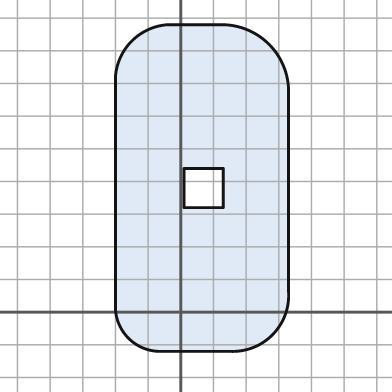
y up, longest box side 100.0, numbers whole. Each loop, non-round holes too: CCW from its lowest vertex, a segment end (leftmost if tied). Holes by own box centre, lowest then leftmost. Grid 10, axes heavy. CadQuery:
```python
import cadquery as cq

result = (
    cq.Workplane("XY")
    .moveTo(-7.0, -12.0)
    .lineTo(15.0, -12.0)
    .threePointArc((28.0, -7.0), (33.0, 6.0))
    .lineTo(33.0, 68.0)
    .threePointArc((27.0, 82.0), (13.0, 88.0))
    .lineTo(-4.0, 88.0)
    .threePointArc((-15.0, 83.0), (-20.0, 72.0))
    .lineTo(-20.0, 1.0)
    .threePointArc((-16.0, -8.0), (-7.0, -12.0))
    .close()
    .moveTo(1.0, 32.0)
    .lineTo(13.0, 32.0)
    .lineTo(13.0, 44.0)
    .lineTo(1.0, 44.0)
    .close()
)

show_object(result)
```